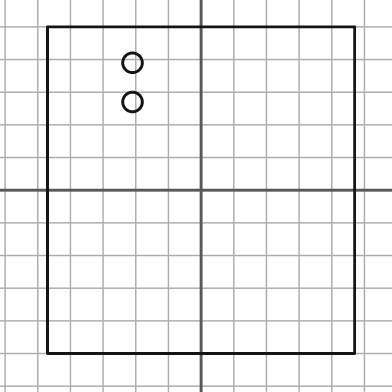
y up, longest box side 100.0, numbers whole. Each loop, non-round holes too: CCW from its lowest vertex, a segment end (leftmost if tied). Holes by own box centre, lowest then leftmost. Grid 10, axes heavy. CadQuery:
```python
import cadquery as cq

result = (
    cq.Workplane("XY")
    .moveTo(-47.0, -50.0)
    .lineTo(47.0, -50.0)
    .lineTo(47.0, 50.0)
    .lineTo(-47.0, 50.0)
    .close()
    .moveTo(-21.0, 27.0)
    .circle(3.0)
    .moveTo(-21.0, 39.0)
    .circle(3.0)
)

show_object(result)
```